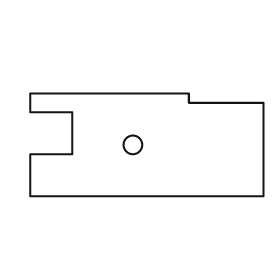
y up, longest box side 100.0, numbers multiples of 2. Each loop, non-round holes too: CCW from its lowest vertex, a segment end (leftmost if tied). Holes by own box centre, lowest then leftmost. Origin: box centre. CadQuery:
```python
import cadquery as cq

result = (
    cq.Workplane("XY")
    .moveTo(-50.0, -22.0)
    .lineTo(50.0, -22.0)
    .lineTo(50.0, 18.0)
    .lineTo(18.0, 18.0)
    .lineTo(18.0, 22.0)
    .lineTo(-50.0, 22.0)
    .lineTo(-50.0, 14.0)
    .lineTo(-32.0, 14.0)
    .lineTo(-32.0, -4.0)
    .lineTo(-50.0, -4.0)
    .close()
    .moveTo(-6.0, 0.0)
    .circle(4.0)
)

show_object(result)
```